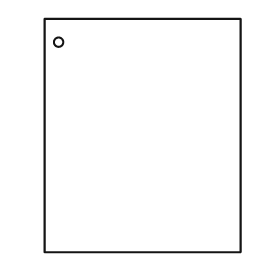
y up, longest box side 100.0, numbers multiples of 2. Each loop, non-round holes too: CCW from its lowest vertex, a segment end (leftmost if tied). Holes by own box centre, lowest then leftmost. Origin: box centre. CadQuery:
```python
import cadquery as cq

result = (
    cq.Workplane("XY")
    .moveTo(-42.0, -50.0)
    .lineTo(42.0, -50.0)
    .lineTo(42.0, 50.0)
    .lineTo(-42.0, 50.0)
    .close()
    .moveTo(-36.0, 40.0)
    .circle(2.0)
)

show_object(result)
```